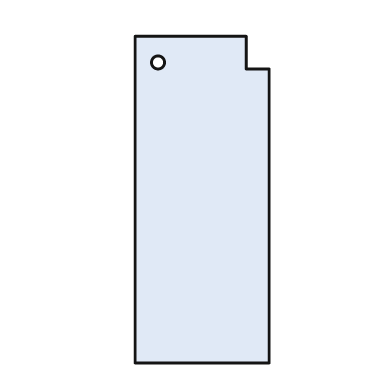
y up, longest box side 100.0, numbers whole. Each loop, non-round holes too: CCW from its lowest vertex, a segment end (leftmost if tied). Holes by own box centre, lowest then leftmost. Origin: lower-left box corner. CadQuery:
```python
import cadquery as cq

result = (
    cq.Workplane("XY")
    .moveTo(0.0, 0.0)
    .lineTo(41.0, 0.0)
    .lineTo(41.0, 90.0)
    .lineTo(34.0, 90.0)
    .lineTo(34.0, 100.0)
    .lineTo(0.0, 100.0)
    .close()
    .moveTo(7.0, 92.0)
    .circle(2.0)
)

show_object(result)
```